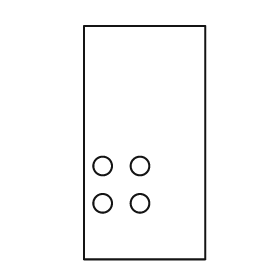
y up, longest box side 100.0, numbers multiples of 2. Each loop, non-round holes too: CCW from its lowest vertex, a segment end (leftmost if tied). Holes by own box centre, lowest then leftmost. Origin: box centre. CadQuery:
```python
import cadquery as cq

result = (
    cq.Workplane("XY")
    .moveTo(-26.0, -50.0)
    .lineTo(26.0, -50.0)
    .lineTo(26.0, 50.0)
    .lineTo(-26.0, 50.0)
    .close()
    .moveTo(-18.0, -26.0)
    .circle(4.0)
    .moveTo(-2.0, -26.0)
    .circle(4.0)
    .moveTo(-18.0, -10.0)
    .circle(4.0)
    .moveTo(-2.0, -10.0)
    .circle(4.0)
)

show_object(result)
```